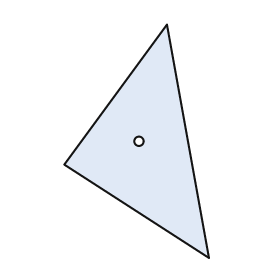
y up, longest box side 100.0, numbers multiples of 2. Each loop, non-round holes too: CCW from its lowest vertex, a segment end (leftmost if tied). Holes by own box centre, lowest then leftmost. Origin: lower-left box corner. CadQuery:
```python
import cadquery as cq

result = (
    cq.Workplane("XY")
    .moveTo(62.0, 0.0)
    .lineTo(44.0, 100.0)
    .lineTo(0.0, 40.0)
    .close()
    .moveTo(32.0, 50.0)
    .circle(2.0)
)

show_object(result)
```